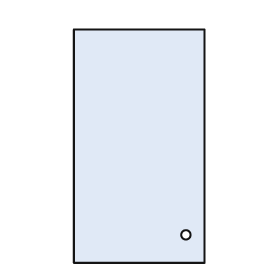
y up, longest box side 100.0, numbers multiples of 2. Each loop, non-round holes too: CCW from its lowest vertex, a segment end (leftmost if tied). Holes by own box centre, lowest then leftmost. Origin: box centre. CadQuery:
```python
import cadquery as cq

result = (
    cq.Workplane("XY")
    .moveTo(-28.0, -50.0)
    .lineTo(28.0, -50.0)
    .lineTo(28.0, 50.0)
    .lineTo(-28.0, 50.0)
    .close()
    .moveTo(20.0, -38.0)
    .circle(2.0)
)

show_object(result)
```